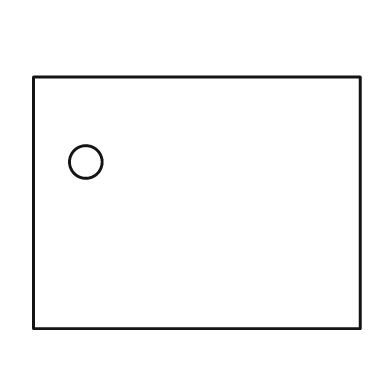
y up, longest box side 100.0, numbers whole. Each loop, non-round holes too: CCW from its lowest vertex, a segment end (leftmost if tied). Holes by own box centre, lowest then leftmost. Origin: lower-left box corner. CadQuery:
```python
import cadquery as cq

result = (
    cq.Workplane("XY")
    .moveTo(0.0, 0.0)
    .lineTo(100.0, 0.0)
    .lineTo(100.0, 77.0)
    .lineTo(0.0, 77.0)
    .close()
    .moveTo(16.0, 51.0)
    .circle(5.0)
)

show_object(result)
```